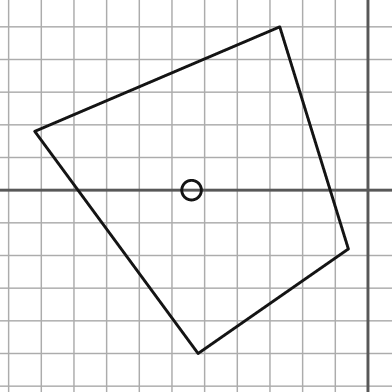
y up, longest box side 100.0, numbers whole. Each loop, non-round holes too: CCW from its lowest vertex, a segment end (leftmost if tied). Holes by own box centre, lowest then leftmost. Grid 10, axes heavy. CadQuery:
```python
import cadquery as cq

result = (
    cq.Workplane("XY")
    .moveTo(-52.0, -50.0)
    .lineTo(-6.0, -18.0)
    .lineTo(-27.0, 50.0)
    .lineTo(-102.0, 18.0)
    .close()
    .moveTo(-54.0, 0.0)
    .circle(3.0)
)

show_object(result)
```